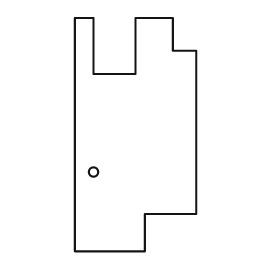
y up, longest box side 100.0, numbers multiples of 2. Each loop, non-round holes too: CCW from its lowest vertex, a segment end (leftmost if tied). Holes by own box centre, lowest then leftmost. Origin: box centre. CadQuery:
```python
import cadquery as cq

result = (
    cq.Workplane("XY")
    .moveTo(-26.0, -50.0)
    .lineTo(4.0, -50.0)
    .lineTo(4.0, -34.0)
    .lineTo(26.0, -34.0)
    .lineTo(26.0, 36.0)
    .lineTo(16.0, 36.0)
    .lineTo(16.0, 50.0)
    .lineTo(0.0, 50.0)
    .lineTo(0.0, 26.0)
    .lineTo(-18.0, 26.0)
    .lineTo(-18.0, 50.0)
    .lineTo(-26.0, 50.0)
    .close()
    .moveTo(-18.0, -16.0)
    .circle(2.0)
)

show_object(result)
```